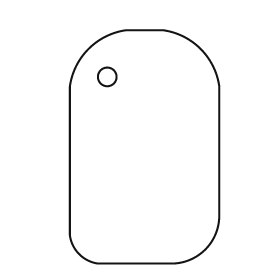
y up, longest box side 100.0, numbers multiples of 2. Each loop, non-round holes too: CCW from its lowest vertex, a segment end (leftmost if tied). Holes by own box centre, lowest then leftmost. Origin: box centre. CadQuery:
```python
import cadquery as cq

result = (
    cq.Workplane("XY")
    .moveTo(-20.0, -50.0)
    .lineTo(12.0, -50.0)
    .threePointArc((26.0, -44.0), (32.0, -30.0))
    .lineTo(32.0, 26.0)
    .threePointArc((24.0, 42.0), (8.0, 50.0))
    .lineTo(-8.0, 50.0)
    .threePointArc((-24.0, 42.0), (-32.0, 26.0))
    .lineTo(-32.0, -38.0)
    .threePointArc((-28.0, -46.0), (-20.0, -50.0))
    .close()
    .moveTo(-16.0, 30.0)
    .circle(4.0)
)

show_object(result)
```